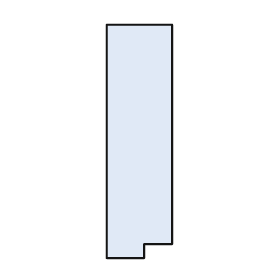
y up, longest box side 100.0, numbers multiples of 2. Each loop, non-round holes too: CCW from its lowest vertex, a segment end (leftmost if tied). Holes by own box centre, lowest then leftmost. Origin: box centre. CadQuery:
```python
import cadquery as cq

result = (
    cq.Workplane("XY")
    .moveTo(-14.0, -50.0)
    .lineTo(2.0, -50.0)
    .lineTo(2.0, -44.0)
    .lineTo(14.0, -44.0)
    .lineTo(14.0, 50.0)
    .lineTo(-14.0, 50.0)
    .close()
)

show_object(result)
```